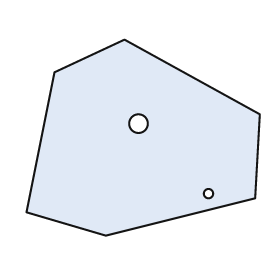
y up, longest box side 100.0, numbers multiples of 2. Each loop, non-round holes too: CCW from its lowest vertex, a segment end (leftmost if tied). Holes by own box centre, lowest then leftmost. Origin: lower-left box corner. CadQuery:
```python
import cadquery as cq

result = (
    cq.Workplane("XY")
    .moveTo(34.0, 0.0)
    .lineTo(98.0, 16.0)
    .lineTo(100.0, 52.0)
    .lineTo(42.0, 84.0)
    .lineTo(12.0, 70.0)
    .lineTo(0.0, 10.0)
    .close()
    .moveTo(78.0, 18.0)
    .circle(2.0)
    .moveTo(48.0, 48.0)
    .circle(4.0)
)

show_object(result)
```